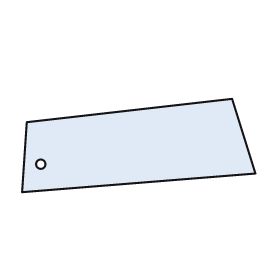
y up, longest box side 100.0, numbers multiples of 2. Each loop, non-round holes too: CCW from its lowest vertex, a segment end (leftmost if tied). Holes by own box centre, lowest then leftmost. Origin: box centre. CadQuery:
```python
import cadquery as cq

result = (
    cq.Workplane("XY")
    .moveTo(-50.0, -20.0)
    .lineTo(50.0, -12.0)
    .lineTo(40.0, 20.0)
    .lineTo(-48.0, 10.0)
    .close()
    .moveTo(-42.0, -8.0)
    .circle(2.0)
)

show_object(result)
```